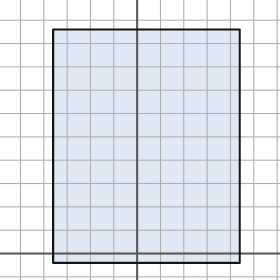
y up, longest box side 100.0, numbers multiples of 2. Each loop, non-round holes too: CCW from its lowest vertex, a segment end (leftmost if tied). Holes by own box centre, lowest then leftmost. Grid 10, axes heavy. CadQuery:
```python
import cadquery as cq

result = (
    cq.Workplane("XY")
    .moveTo(-36.0, -4.0)
    .lineTo(44.0, -4.0)
    .lineTo(44.0, 96.0)
    .lineTo(-36.0, 96.0)
    .close()
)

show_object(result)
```